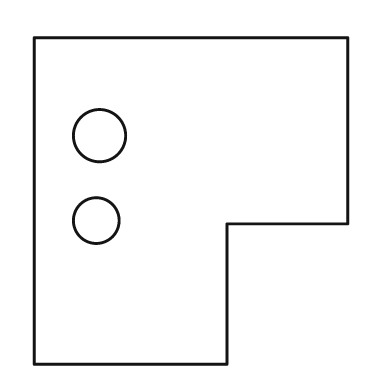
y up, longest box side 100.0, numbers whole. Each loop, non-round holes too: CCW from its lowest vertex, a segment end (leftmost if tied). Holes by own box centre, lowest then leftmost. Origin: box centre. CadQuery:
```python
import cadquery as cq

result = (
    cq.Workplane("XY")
    .moveTo(-48.0, -50.0)
    .lineTo(11.0, -50.0)
    .lineTo(11.0, -7.0)
    .lineTo(48.0, -7.0)
    .lineTo(48.0, 50.0)
    .lineTo(-48.0, 50.0)
    .close()
    .moveTo(-29.0, -6.0)
    .circle(7.0)
    .moveTo(-28.0, 20.0)
    .circle(8.0)
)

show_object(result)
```